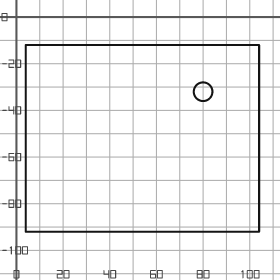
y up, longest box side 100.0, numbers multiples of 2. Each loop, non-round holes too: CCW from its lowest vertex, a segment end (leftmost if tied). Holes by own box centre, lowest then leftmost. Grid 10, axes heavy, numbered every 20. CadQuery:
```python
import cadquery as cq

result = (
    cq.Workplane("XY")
    .moveTo(4.0, -92.0)
    .lineTo(104.0, -92.0)
    .lineTo(104.0, -12.0)
    .lineTo(4.0, -12.0)
    .close()
    .moveTo(80.0, -32.0)
    .circle(4.0)
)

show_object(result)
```